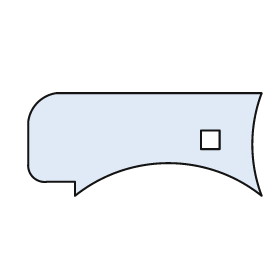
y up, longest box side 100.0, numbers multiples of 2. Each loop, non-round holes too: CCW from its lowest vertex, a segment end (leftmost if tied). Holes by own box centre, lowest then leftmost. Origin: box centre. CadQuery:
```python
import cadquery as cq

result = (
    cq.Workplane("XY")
    .moveTo(-30.0, -22.0)
    .threePointArc((10.0, -8.0), (50.0, -22.0))
    .threePointArc((46.0, 0.0), (50.0, 22.0))
    .lineTo(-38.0, 22.0)
    .threePointArc((-46.0, 18.0), (-50.0, 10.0))
    .lineTo(-50.0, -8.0)
    .threePointArc((-48.0, -14.0), (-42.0, -16.0))
    .lineTo(-30.0, -16.0)
    .close()
    .moveTo(24.0, -2.0)
    .lineTo(32.0, -2.0)
    .lineTo(32.0, 6.0)
    .lineTo(24.0, 6.0)
    .close()
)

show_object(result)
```